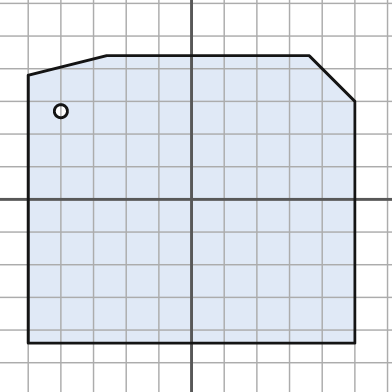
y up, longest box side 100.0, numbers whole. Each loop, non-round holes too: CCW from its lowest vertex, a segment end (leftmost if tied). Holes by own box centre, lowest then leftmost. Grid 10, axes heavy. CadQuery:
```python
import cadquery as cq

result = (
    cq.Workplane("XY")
    .moveTo(-50.0, -44.0)
    .lineTo(50.0, -44.0)
    .lineTo(50.0, 30.0)
    .lineTo(36.0, 44.0)
    .lineTo(-26.0, 44.0)
    .lineTo(-50.0, 38.0)
    .close()
    .moveTo(-40.0, 27.0)
    .circle(2.0)
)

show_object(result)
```